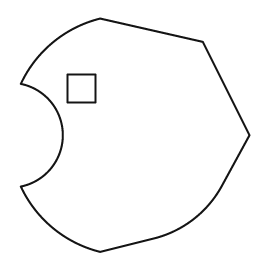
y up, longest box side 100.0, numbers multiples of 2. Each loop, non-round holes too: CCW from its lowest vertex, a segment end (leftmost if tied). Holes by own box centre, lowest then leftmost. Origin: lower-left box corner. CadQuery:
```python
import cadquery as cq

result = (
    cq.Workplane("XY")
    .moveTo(34.0, 0.0)
    .lineTo(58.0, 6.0)
    .threePointArc((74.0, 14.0), (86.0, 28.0))
    .lineTo(98.0, 50.0)
    .lineTo(78.0, 90.0)
    .lineTo(34.0, 100.0)
    .threePointArc((14.0, 90.0), (0.0, 72.0))
    .threePointArc((18.0, 50.0), (0.0, 28.0))
    .threePointArc((14.0, 10.0), (34.0, 0.0))
    .close()
    .moveTo(20.0, 64.0)
    .lineTo(32.0, 64.0)
    .lineTo(32.0, 76.0)
    .lineTo(20.0, 76.0)
    .close()
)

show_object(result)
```